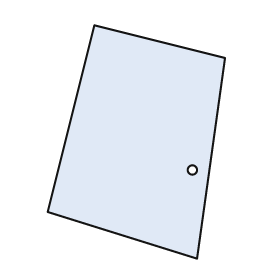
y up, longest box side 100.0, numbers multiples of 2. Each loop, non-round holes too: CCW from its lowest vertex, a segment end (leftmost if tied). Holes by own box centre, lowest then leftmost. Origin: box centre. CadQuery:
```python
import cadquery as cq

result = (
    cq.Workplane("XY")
    .moveTo(26.0, -50.0)
    .lineTo(38.0, 36.0)
    .lineTo(-18.0, 50.0)
    .lineTo(-38.0, -30.0)
    .close()
    .moveTo(24.0, -12.0)
    .circle(2.0)
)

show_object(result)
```